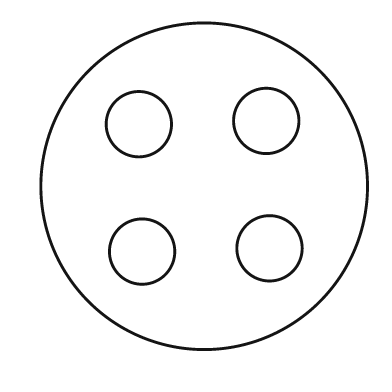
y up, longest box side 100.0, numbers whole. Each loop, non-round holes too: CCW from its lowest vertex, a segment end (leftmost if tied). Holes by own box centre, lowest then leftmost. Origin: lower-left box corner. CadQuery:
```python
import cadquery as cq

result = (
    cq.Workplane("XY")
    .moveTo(50.0, 50.0)
    .circle(50.0)
    .moveTo(31.0, 30.0)
    .circle(10.0)
    .moveTo(70.0, 31.0)
    .circle(10.0)
    .moveTo(30.0, 69.0)
    .circle(10.0)
    .moveTo(69.0, 70.0)
    .circle(10.0)
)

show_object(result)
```